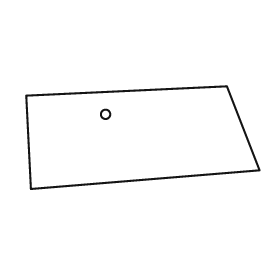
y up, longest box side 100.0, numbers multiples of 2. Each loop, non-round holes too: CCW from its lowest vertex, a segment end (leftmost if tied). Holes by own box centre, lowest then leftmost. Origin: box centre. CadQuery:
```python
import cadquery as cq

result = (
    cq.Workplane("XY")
    .moveTo(-48.0, -22.0)
    .lineTo(50.0, -14.0)
    .lineTo(36.0, 22.0)
    .lineTo(-50.0, 18.0)
    .close()
    .moveTo(-16.0, 10.0)
    .circle(2.0)
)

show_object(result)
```